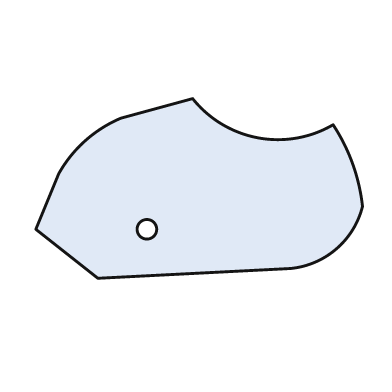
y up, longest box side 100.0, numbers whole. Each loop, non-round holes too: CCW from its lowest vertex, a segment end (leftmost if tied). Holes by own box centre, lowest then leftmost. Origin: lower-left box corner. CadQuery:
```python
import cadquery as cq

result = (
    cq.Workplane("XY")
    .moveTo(19.0, 0.0)
    .lineTo(78.0, 3.0)
    .threePointArc((92.0, 9.0), (100.0, 22.0))
    .threePointArc((97.0, 35.0), (91.0, 47.0))
    .threePointArc((68.0, 43.0), (48.0, 55.0))
    .lineTo(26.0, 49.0)
    .threePointArc((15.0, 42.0), (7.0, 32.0))
    .lineTo(0.0, 15.0)
    .close()
    .moveTo(34.0, 15.0)
    .circle(3.0)
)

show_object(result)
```